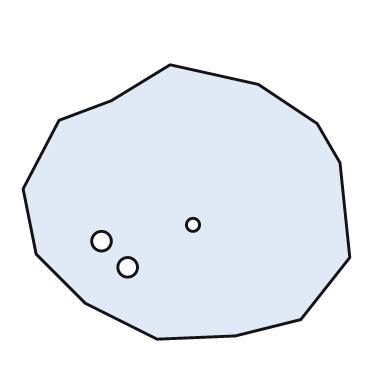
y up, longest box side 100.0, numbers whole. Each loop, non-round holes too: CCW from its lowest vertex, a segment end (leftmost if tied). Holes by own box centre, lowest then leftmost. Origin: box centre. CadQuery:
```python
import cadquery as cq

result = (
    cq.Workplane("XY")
    .moveTo(-9.0, -42.0)
    .lineTo(15.0, -41.0)
    .lineTo(35.0, -36.0)
    .lineTo(50.0, -17.0)
    .lineTo(47.0, 12.0)
    .lineTo(40.0, 24.0)
    .lineTo(22.0, 36.0)
    .lineTo(-5.0, 42.0)
    .lineTo(-23.0, 31.0)
    .lineTo(-39.0, 25.0)
    .lineTo(-50.0, 4.0)
    .lineTo(-46.0, -16.0)
    .lineTo(-31.0, -31.0)
    .close()
    .moveTo(-18.0, -20.0)
    .circle(3.0)
    .moveTo(-26.0, -12.0)
    .circle(3.0)
    .moveTo(2.0, -7.0)
    .circle(2.0)
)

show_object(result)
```